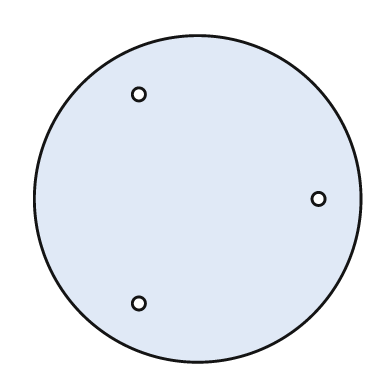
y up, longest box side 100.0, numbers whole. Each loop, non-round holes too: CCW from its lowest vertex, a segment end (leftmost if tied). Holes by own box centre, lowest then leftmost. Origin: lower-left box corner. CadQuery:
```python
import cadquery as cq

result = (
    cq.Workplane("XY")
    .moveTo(50.0, 50.0)
    .circle(50.0)
    .moveTo(32.0, 18.0)
    .circle(2.0)
    .moveTo(87.0, 50.0)
    .circle(2.0)
    .moveTo(32.0, 82.0)
    .circle(2.0)
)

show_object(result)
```